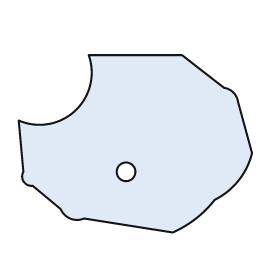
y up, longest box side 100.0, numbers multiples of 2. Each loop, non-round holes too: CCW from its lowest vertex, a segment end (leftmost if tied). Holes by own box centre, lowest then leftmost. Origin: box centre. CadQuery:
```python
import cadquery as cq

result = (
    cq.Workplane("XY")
    .moveTo(16.0, -38.0)
    .threePointArc((26.0, -32.0), (34.0, -24.0))
    .threePointArc((44.0, -16.0), (50.0, -4.0))
    .lineTo(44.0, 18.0)
    .threePointArc((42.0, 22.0), (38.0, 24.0))
    .lineTo(20.0, 38.0)
    .lineTo(-20.0, 38.0)
    .threePointArc((-26.0, 14.0), (-50.0, 10.0))
    .lineTo(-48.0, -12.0)
    .threePointArc((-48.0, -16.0), (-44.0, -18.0))
    .lineTo(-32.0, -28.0)
    .threePointArc((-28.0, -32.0), (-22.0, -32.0))
    .close()
    .moveTo(-4.0, -12.0)
    .circle(4.0)
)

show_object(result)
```